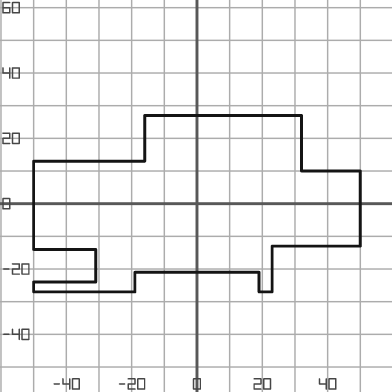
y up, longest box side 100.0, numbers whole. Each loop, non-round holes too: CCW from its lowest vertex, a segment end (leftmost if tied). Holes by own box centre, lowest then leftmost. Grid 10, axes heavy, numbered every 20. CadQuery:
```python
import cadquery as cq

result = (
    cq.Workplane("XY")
    .moveTo(-50.0, -27.0)
    .lineTo(-19.0, -27.0)
    .lineTo(-19.0, -21.0)
    .lineTo(19.0, -21.0)
    .lineTo(19.0, -27.0)
    .lineTo(23.0, -27.0)
    .lineTo(23.0, -13.0)
    .lineTo(50.0, -13.0)
    .lineTo(50.0, 10.0)
    .lineTo(32.0, 10.0)
    .lineTo(32.0, 27.0)
    .lineTo(-16.0, 27.0)
    .lineTo(-16.0, 13.0)
    .lineTo(-50.0, 13.0)
    .lineTo(-50.0, -14.0)
    .lineTo(-31.0, -14.0)
    .lineTo(-31.0, -24.0)
    .lineTo(-50.0, -24.0)
    .close()
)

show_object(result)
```